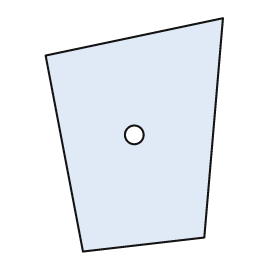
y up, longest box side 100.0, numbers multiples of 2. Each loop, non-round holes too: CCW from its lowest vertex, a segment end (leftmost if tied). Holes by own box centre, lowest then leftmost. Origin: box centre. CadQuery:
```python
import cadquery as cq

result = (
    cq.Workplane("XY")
    .moveTo(-22.0, -50.0)
    .lineTo(30.0, -44.0)
    .lineTo(38.0, 50.0)
    .lineTo(-38.0, 34.0)
    .close()
    .moveTo(0.0, 0.0)
    .circle(4.0)
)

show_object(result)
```